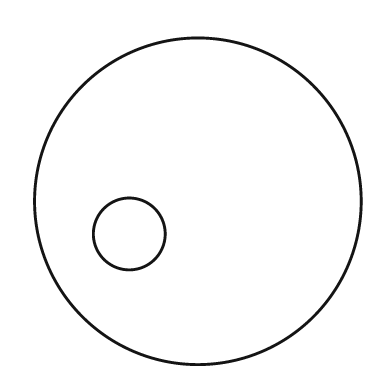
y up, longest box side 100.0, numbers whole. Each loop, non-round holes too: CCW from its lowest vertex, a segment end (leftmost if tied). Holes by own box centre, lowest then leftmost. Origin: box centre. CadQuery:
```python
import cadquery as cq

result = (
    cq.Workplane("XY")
    .moveTo(0.0, 0.0)
    .circle(50.0)
    .moveTo(-21.0, -10.0)
    .circle(11.0)
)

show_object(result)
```